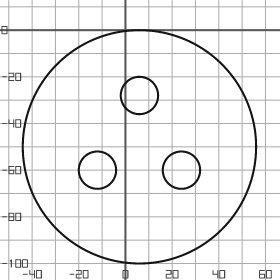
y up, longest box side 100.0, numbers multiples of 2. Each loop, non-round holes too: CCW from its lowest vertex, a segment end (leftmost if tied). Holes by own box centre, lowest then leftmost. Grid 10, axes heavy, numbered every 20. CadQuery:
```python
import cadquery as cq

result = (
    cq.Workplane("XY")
    .moveTo(6.0, -50.0)
    .circle(50.0)
    .moveTo(-12.0, -60.0)
    .circle(8.0)
    .moveTo(24.0, -60.0)
    .circle(8.0)
    .moveTo(6.0, -28.0)
    .circle(8.0)
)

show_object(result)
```